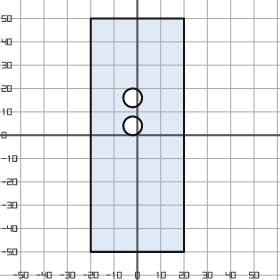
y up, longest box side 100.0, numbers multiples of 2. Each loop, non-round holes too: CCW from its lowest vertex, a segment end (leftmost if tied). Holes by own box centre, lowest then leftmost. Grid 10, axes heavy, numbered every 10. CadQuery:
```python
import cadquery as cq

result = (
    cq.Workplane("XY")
    .moveTo(-20.0, -50.0)
    .lineTo(20.0, -50.0)
    .lineTo(20.0, 50.0)
    .lineTo(-20.0, 50.0)
    .close()
    .moveTo(-2.0, 4.0)
    .circle(4.0)
    .moveTo(-2.0, 16.0)
    .circle(4.0)
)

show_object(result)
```